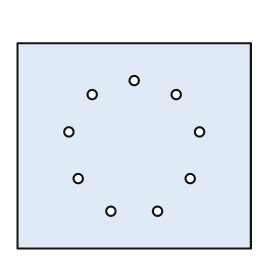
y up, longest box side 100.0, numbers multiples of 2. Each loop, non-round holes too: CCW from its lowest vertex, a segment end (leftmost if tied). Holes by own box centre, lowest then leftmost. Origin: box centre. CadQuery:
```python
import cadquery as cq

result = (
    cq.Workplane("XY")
    .moveTo(-50.0, -44.0)
    .lineTo(50.0, -44.0)
    .lineTo(50.0, 44.0)
    .lineTo(-50.0, 44.0)
    .close()
    .moveTo(-10.0, -28.0)
    .circle(2.0)
    .moveTo(10.0, -28.0)
    .circle(2.0)
    .moveTo(-24.0, -14.0)
    .circle(2.0)
    .moveTo(24.0, -14.0)
    .circle(2.0)
    .moveTo(-28.0, 6.0)
    .circle(2.0)
    .moveTo(28.0, 6.0)
    .circle(2.0)
    .moveTo(-18.0, 22.0)
    .circle(2.0)
    .moveTo(18.0, 22.0)
    .circle(2.0)
    .moveTo(0.0, 28.0)
    .circle(2.0)
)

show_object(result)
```